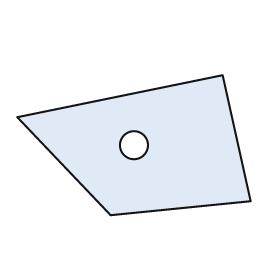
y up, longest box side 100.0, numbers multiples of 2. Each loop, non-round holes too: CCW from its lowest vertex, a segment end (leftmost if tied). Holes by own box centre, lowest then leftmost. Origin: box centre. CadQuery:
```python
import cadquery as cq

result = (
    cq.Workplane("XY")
    .moveTo(-10.0, -30.0)
    .lineTo(50.0, -24.0)
    .lineTo(38.0, 30.0)
    .lineTo(-50.0, 12.0)
    .close()
    .moveTo(0.0, 0.0)
    .circle(6.0)
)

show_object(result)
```